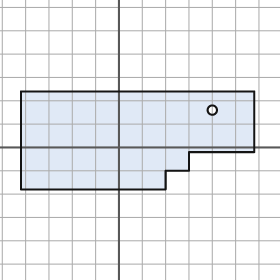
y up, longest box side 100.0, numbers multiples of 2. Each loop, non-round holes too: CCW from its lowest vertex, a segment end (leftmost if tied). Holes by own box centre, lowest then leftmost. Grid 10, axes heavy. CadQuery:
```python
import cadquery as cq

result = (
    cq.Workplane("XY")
    .moveTo(-42.0, -18.0)
    .lineTo(20.0, -18.0)
    .lineTo(20.0, -10.0)
    .lineTo(30.0, -10.0)
    .lineTo(30.0, -2.0)
    .lineTo(58.0, -2.0)
    .lineTo(58.0, 24.0)
    .lineTo(-42.0, 24.0)
    .close()
    .moveTo(40.0, 16.0)
    .circle(2.0)
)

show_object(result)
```